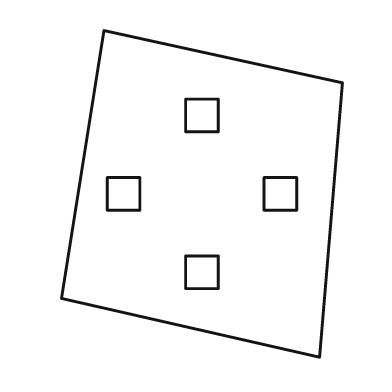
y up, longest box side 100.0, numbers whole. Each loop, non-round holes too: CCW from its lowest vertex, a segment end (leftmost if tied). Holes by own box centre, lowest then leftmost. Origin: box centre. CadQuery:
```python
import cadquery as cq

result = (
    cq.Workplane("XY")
    .moveTo(36.0, -50.0)
    .lineTo(43.0, 34.0)
    .lineTo(-30.0, 50.0)
    .lineTo(-43.0, -32.0)
    .close()
    .moveTo(-5.0, -29.0)
    .lineTo(5.0, -29.0)
    .lineTo(5.0, -19.0)
    .lineTo(-5.0, -19.0)
    .close()
    .moveTo(-29.0, -5.0)
    .lineTo(-19.0, -5.0)
    .lineTo(-19.0, 5.0)
    .lineTo(-29.0, 5.0)
    .close()
    .moveTo(19.0, -5.0)
    .lineTo(29.0, -5.0)
    .lineTo(29.0, 5.0)
    .lineTo(19.0, 5.0)
    .close()
    .moveTo(-5.0, 19.0)
    .lineTo(5.0, 19.0)
    .lineTo(5.0, 29.0)
    .lineTo(-5.0, 29.0)
    .close()
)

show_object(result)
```